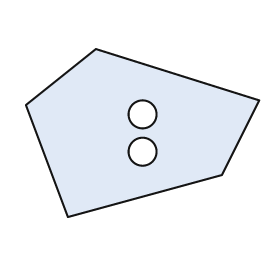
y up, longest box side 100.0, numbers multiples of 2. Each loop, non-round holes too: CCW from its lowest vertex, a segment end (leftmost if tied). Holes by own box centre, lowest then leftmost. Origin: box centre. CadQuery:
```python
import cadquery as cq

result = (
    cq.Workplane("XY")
    .moveTo(-32.0, -36.0)
    .lineTo(34.0, -18.0)
    .lineTo(50.0, 14.0)
    .lineTo(-20.0, 36.0)
    .lineTo(-50.0, 12.0)
    .close()
    .moveTo(0.0, -8.0)
    .circle(6.0)
    .moveTo(0.0, 8.0)
    .circle(6.0)
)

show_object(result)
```